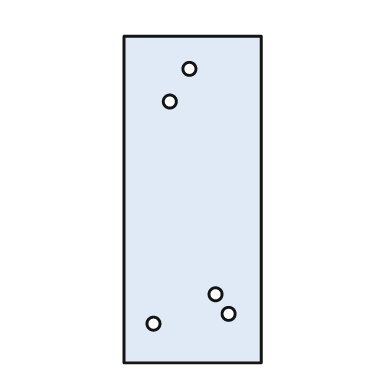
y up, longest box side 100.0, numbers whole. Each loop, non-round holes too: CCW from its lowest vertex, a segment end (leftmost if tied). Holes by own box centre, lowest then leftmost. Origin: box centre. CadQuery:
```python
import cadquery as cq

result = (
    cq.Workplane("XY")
    .moveTo(-21.0, -50.0)
    .lineTo(21.0, -50.0)
    .lineTo(21.0, 50.0)
    .lineTo(-21.0, 50.0)
    .close()
    .moveTo(-12.0, -38.0)
    .circle(2.0)
    .moveTo(11.0, -35.0)
    .circle(2.0)
    .moveTo(7.0, -29.0)
    .circle(2.0)
    .moveTo(-7.0, 30.0)
    .circle(2.0)
    .moveTo(-1.0, 40.0)
    .circle(2.0)
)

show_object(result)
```